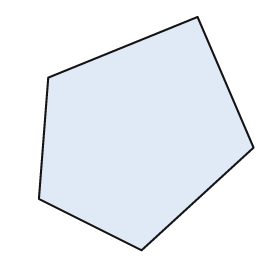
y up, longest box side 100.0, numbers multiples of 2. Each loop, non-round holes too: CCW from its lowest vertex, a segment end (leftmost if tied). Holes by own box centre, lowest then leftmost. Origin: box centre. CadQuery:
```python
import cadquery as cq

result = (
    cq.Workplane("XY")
    .moveTo(-2.0, -50.0)
    .lineTo(46.0, -6.0)
    .lineTo(22.0, 50.0)
    .lineTo(-42.0, 24.0)
    .lineTo(-46.0, -28.0)
    .close()
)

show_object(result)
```